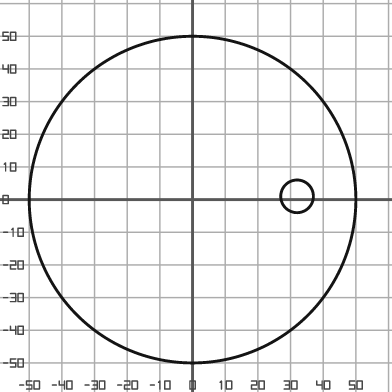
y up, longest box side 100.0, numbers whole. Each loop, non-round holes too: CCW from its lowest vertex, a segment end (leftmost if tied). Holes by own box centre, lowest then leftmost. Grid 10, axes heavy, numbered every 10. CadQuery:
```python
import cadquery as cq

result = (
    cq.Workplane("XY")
    .moveTo(0.0, 0.0)
    .circle(50.0)
    .moveTo(32.0, 1.0)
    .circle(5.0)
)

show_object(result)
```